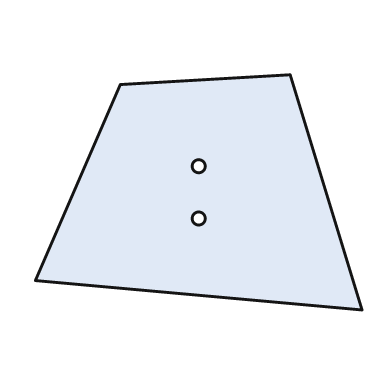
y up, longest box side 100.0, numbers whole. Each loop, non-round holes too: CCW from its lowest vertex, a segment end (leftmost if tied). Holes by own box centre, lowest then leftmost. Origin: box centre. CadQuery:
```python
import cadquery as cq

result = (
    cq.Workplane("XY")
    .moveTo(50.0, -36.0)
    .lineTo(28.0, 36.0)
    .lineTo(-24.0, 33.0)
    .lineTo(-50.0, -27.0)
    .close()
    .moveTo(0.0, -8.0)
    .circle(2.0)
    .moveTo(0.0, 8.0)
    .circle(2.0)
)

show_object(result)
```